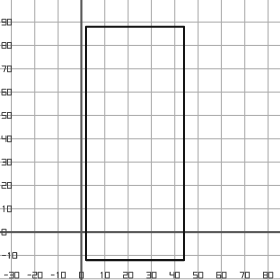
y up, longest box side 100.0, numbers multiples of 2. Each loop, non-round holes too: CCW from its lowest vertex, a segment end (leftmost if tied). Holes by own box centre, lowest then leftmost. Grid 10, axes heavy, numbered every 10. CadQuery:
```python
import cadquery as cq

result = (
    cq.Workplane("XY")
    .moveTo(2.0, -12.0)
    .lineTo(44.0, -12.0)
    .lineTo(44.0, 88.0)
    .lineTo(2.0, 88.0)
    .close()
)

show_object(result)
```